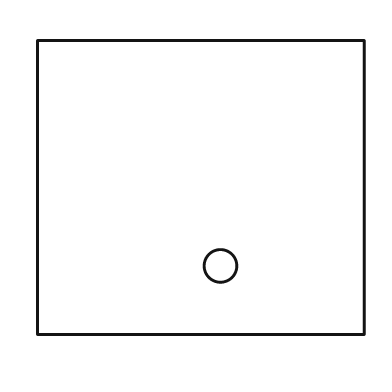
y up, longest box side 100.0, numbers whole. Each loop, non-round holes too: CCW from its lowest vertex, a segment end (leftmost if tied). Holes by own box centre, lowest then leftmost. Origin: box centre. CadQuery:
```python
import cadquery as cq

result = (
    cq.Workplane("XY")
    .moveTo(-50.0, -45.0)
    .lineTo(50.0, -45.0)
    .lineTo(50.0, 45.0)
    .lineTo(-50.0, 45.0)
    .close()
    .moveTo(6.0, -24.0)
    .circle(5.0)
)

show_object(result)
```